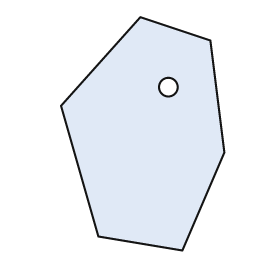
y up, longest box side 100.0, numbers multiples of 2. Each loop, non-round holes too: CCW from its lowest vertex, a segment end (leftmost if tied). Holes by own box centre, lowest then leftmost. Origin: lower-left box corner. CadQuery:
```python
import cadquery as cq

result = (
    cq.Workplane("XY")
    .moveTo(52.0, 0.0)
    .lineTo(70.0, 42.0)
    .lineTo(64.0, 90.0)
    .lineTo(34.0, 100.0)
    .lineTo(0.0, 62.0)
    .lineTo(16.0, 6.0)
    .close()
    .moveTo(46.0, 70.0)
    .circle(4.0)
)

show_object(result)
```